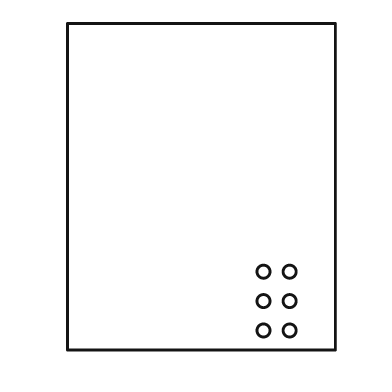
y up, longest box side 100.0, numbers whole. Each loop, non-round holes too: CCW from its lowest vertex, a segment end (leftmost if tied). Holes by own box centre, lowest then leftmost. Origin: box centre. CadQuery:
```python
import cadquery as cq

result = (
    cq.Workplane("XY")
    .moveTo(-41.0, -50.0)
    .lineTo(41.0, -50.0)
    .lineTo(41.0, 50.0)
    .lineTo(-41.0, 50.0)
    .close()
    .moveTo(19.0, -44.0)
    .circle(2.0)
    .moveTo(27.0, -44.0)
    .circle(2.0)
    .moveTo(19.0, -35.0)
    .circle(2.0)
    .moveTo(27.0, -35.0)
    .circle(2.0)
    .moveTo(19.0, -26.0)
    .circle(2.0)
    .moveTo(27.0, -26.0)
    .circle(2.0)
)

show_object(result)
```